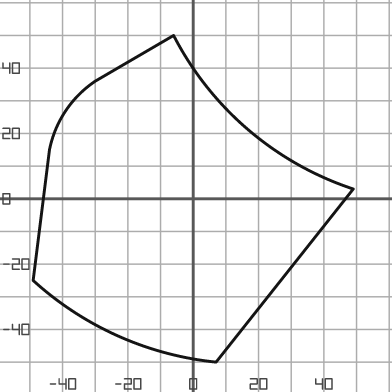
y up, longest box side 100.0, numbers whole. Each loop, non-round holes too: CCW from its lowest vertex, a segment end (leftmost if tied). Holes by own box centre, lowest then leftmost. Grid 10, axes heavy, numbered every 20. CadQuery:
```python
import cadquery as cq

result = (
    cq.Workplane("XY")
    .moveTo(7.0, -50.0)
    .lineTo(49.0, 3.0)
    .threePointArc((17.0, 21.0), (-6.0, 50.0))
    .lineTo(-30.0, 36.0)
    .threePointArc((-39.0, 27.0), (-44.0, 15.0))
    .lineTo(-49.0, -25.0)
    .threePointArc((-23.0, -42.0), (7.0, -50.0))
    .close()
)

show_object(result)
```